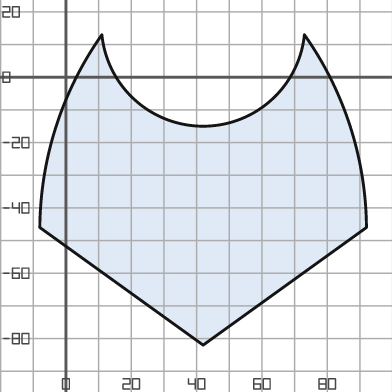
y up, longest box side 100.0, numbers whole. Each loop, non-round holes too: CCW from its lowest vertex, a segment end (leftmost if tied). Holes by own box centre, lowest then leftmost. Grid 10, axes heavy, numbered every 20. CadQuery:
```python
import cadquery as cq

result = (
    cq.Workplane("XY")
    .moveTo(42.0, -82.0)
    .lineTo(92.0, -46.0)
    .threePointArc((87.0, -15.0), (73.0, 13.0))
    .threePointArc((42.0, -15.0), (11.0, 13.0))
    .threePointArc((-3.0, -15.0), (-8.0, -46.0))
    .close()
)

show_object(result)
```